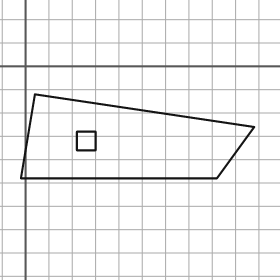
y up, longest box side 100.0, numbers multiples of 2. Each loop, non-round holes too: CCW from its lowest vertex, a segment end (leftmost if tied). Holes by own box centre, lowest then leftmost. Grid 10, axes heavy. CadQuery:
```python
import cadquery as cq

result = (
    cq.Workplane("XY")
    .moveTo(-2.0, -48.0)
    .lineTo(82.0, -48.0)
    .lineTo(98.0, -26.0)
    .lineTo(4.0, -12.0)
    .close()
    .moveTo(22.0, -36.0)
    .lineTo(30.0, -36.0)
    .lineTo(30.0, -28.0)
    .lineTo(22.0, -28.0)
    .close()
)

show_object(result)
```